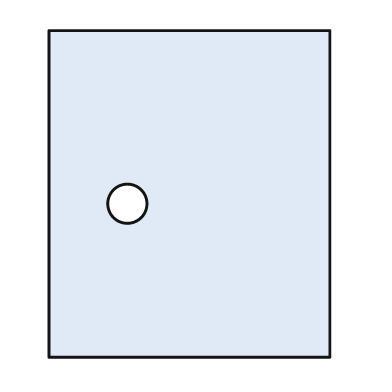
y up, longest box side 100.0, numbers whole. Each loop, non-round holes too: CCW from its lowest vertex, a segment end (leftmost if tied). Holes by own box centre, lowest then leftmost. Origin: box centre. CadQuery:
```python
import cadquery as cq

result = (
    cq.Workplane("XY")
    .moveTo(-43.0, -50.0)
    .lineTo(43.0, -50.0)
    .lineTo(43.0, 50.0)
    .lineTo(-43.0, 50.0)
    .close()
    .moveTo(-19.0, -3.0)
    .circle(6.0)
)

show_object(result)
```